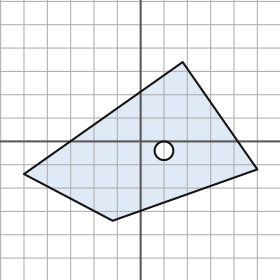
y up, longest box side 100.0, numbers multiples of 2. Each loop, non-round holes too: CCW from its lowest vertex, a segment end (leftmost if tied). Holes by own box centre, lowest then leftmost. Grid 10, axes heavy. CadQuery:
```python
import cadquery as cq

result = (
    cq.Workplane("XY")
    .moveTo(-12.0, -34.0)
    .lineTo(50.0, -12.0)
    .lineTo(18.0, 34.0)
    .lineTo(-50.0, -14.0)
    .close()
    .moveTo(10.0, -4.0)
    .circle(4.0)
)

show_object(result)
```